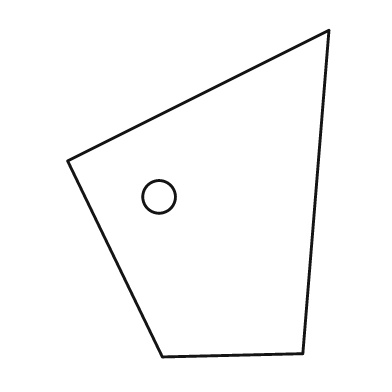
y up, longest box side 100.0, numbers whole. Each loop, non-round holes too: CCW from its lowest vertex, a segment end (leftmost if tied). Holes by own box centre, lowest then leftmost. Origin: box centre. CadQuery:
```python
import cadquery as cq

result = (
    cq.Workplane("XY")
    .moveTo(-11.0, -50.0)
    .lineTo(32.0, -49.0)
    .lineTo(40.0, 50.0)
    .lineTo(-40.0, 10.0)
    .close()
    .moveTo(-12.0, -1.0)
    .circle(5.0)
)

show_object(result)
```